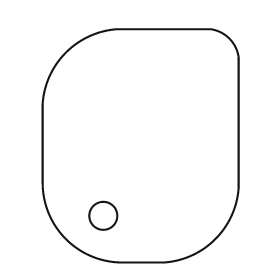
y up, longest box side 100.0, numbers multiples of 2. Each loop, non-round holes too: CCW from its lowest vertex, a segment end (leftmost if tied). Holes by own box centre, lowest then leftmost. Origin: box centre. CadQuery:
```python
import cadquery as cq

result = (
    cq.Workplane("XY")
    .moveTo(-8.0, -50.0)
    .lineTo(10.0, -50.0)
    .threePointArc((32.0, -40.0), (42.0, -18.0))
    .lineTo(42.0, 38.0)
    .threePointArc((38.0, 46.0), (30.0, 50.0))
    .lineTo(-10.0, 50.0)
    .threePointArc((-32.0, 40.0), (-42.0, 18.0))
    .lineTo(-42.0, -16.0)
    .threePointArc((-32.0, -40.0), (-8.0, -50.0))
    .close()
    .moveTo(-16.0, -30.0)
    .circle(6.0)
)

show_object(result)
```